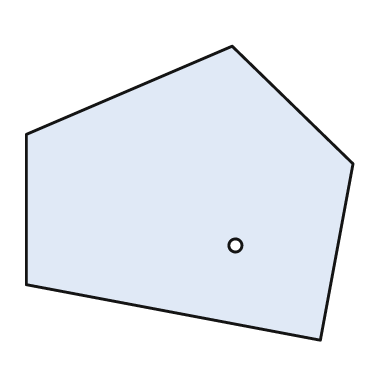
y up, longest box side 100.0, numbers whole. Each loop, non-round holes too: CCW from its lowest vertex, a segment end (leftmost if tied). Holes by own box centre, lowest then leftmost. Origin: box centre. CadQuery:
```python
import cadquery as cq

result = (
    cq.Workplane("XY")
    .moveTo(40.0, -45.0)
    .lineTo(50.0, 9.0)
    .lineTo(13.0, 45.0)
    .lineTo(-50.0, 18.0)
    .lineTo(-50.0, -28.0)
    .close()
    .moveTo(14.0, -16.0)
    .circle(2.0)
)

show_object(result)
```